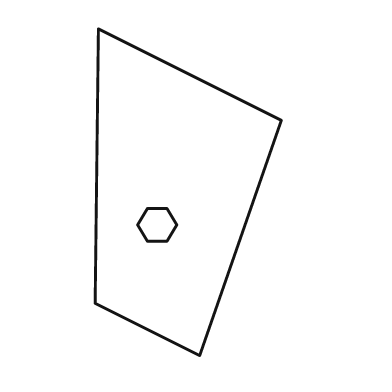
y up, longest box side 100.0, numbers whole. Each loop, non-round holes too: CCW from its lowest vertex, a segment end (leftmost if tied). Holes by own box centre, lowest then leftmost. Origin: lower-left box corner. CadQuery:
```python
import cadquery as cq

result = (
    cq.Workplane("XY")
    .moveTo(32.0, 0.0)
    .lineTo(57.0, 72.0)
    .lineTo(1.0, 100.0)
    .lineTo(0.0, 16.0)
    .close()
    .moveTo(16.0, 35.0)
    .lineTo(22.0, 35.0)
    .lineTo(25.0, 40.0)
    .lineTo(22.0, 45.0)
    .lineTo(16.0, 45.0)
    .lineTo(13.0, 40.0)
    .close()
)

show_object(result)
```